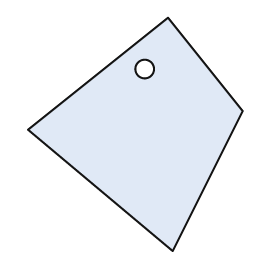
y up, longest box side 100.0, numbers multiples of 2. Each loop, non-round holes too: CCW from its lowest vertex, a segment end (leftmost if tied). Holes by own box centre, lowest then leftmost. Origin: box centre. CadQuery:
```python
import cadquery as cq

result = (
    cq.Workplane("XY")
    .moveTo(16.0, -50.0)
    .lineTo(46.0, 10.0)
    .lineTo(14.0, 50.0)
    .lineTo(-46.0, 2.0)
    .close()
    .moveTo(4.0, 28.0)
    .circle(4.0)
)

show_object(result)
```